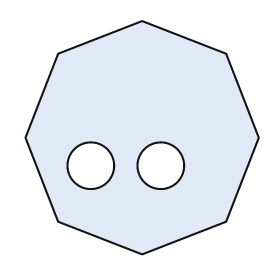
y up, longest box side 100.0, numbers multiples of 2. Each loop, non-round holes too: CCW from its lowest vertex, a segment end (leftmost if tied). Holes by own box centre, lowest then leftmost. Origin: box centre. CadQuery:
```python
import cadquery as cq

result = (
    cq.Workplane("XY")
    .moveTo(0.0, -50.0)
    .lineTo(36.0, -36.0)
    .lineTo(50.0, 0.0)
    .lineTo(36.0, 36.0)
    .lineTo(0.0, 50.0)
    .lineTo(-36.0, 36.0)
    .lineTo(-50.0, 0.0)
    .lineTo(-36.0, -36.0)
    .close()
    .moveTo(-22.0, -12.0)
    .circle(10.0)
    .moveTo(8.0, -12.0)
    .circle(10.0)
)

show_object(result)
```